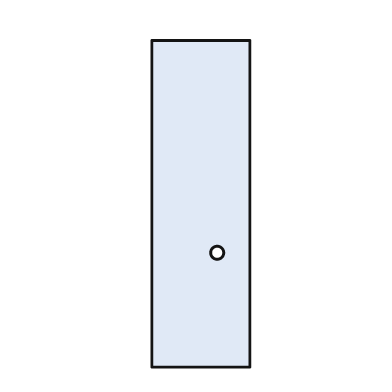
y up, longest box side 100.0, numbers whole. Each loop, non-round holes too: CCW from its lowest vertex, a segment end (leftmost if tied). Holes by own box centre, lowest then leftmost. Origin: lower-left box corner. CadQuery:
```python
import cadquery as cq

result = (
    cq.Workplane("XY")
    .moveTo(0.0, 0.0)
    .lineTo(30.0, 0.0)
    .lineTo(30.0, 100.0)
    .lineTo(0.0, 100.0)
    .close()
    .moveTo(20.0, 35.0)
    .circle(2.0)
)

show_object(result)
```